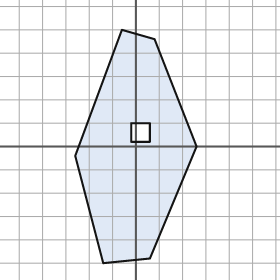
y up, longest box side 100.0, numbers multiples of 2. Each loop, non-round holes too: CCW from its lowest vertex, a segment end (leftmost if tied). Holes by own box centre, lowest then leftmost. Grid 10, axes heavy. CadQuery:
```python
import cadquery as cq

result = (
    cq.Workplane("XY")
    .moveTo(-14.0, -50.0)
    .lineTo(6.0, -48.0)
    .lineTo(26.0, 0.0)
    .lineTo(8.0, 46.0)
    .lineTo(-6.0, 50.0)
    .lineTo(-26.0, -4.0)
    .close()
    .moveTo(-2.0, 2.0)
    .lineTo(6.0, 2.0)
    .lineTo(6.0, 10.0)
    .lineTo(-2.0, 10.0)
    .close()
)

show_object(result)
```